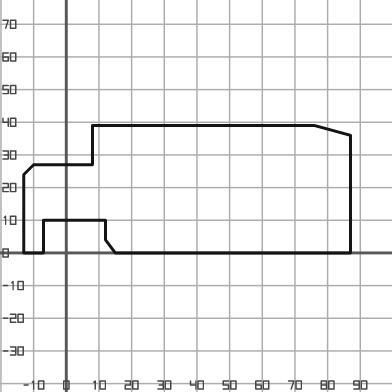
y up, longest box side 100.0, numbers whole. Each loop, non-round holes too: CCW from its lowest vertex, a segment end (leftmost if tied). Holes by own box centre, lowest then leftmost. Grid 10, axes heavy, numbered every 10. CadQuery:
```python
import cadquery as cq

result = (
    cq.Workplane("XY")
    .moveTo(-13.0, 0.0)
    .lineTo(-7.0, 0.0)
    .lineTo(-7.0, 10.0)
    .lineTo(12.0, 10.0)
    .lineTo(12.0, 4.0)
    .lineTo(15.0, 0.0)
    .lineTo(87.0, 0.0)
    .lineTo(87.0, 36.0)
    .lineTo(76.0, 39.0)
    .lineTo(8.0, 39.0)
    .lineTo(8.0, 27.0)
    .lineTo(-10.0, 27.0)
    .lineTo(-13.0, 24.0)
    .close()
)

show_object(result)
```